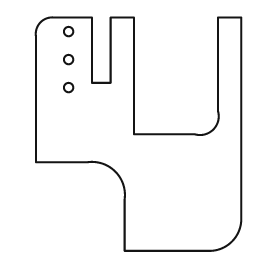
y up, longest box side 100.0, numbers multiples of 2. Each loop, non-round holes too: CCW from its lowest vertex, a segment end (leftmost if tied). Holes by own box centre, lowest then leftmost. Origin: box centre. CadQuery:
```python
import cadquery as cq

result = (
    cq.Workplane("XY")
    .moveTo(-6.0, -50.0)
    .lineTo(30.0, -50.0)
    .threePointArc((40.0, -46.0), (44.0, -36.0))
    .lineTo(44.0, 50.0)
    .lineTo(34.0, 50.0)
    .lineTo(34.0, 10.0)
    .threePointArc((32.0, 2.0), (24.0, 0.0))
    .lineTo(-2.0, 0.0)
    .lineTo(-2.0, 50.0)
    .lineTo(-12.0, 50.0)
    .lineTo(-12.0, 22.0)
    .lineTo(-20.0, 22.0)
    .lineTo(-20.0, 50.0)
    .lineTo(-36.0, 50.0)
    .threePointArc((-42.0, 48.0), (-44.0, 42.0))
    .lineTo(-44.0, -12.0)
    .lineTo(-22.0, -12.0)
    .threePointArc((-10.0, -16.0), (-6.0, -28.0))
    .close()
    .moveTo(-30.0, 20.0)
    .circle(2.0)
    .moveTo(-30.0, 32.0)
    .circle(2.0)
    .moveTo(-30.0, 44.0)
    .circle(2.0)
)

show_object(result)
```